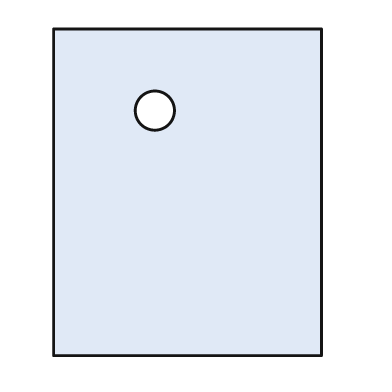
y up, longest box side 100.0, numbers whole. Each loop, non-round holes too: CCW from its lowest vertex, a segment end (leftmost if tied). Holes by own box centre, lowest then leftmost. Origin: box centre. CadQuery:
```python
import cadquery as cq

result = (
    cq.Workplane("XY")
    .moveTo(-41.0, -50.0)
    .lineTo(41.0, -50.0)
    .lineTo(41.0, 50.0)
    .lineTo(-41.0, 50.0)
    .close()
    .moveTo(-10.0, 25.0)
    .circle(6.0)
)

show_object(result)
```